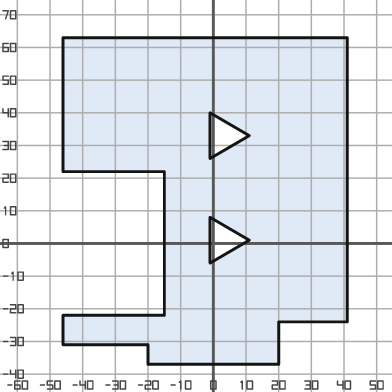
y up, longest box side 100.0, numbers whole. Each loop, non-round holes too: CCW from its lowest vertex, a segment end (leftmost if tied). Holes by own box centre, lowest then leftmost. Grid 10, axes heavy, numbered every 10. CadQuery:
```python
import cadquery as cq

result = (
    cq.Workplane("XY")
    .moveTo(-20.0, -37.0)
    .lineTo(20.0, -37.0)
    .lineTo(20.0, -24.0)
    .lineTo(41.0, -24.0)
    .lineTo(41.0, 63.0)
    .lineTo(-46.0, 63.0)
    .lineTo(-46.0, 22.0)
    .lineTo(-15.0, 22.0)
    .lineTo(-15.0, -22.0)
    .lineTo(-46.0, -22.0)
    .lineTo(-46.0, -31.0)
    .lineTo(-20.0, -31.0)
    .close()
    .moveTo(-1.0, -6.0)
    .lineTo(11.0, 1.0)
    .lineTo(-1.0, 8.0)
    .close()
    .moveTo(-1.0, 26.0)
    .lineTo(11.0, 33.0)
    .lineTo(-1.0, 40.0)
    .close()
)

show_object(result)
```